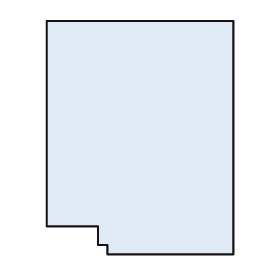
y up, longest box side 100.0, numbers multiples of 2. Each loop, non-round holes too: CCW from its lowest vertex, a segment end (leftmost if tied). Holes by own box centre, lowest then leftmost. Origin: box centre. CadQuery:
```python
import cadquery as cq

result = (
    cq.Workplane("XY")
    .moveTo(-14.0, -50.0)
    .lineTo(40.0, -50.0)
    .lineTo(40.0, 50.0)
    .lineTo(-40.0, 50.0)
    .lineTo(-40.0, -38.0)
    .lineTo(-18.0, -38.0)
    .lineTo(-18.0, -46.0)
    .lineTo(-14.0, -46.0)
    .close()
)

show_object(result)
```